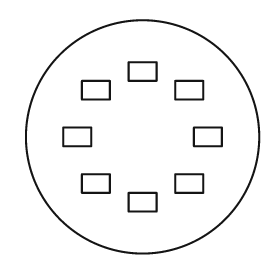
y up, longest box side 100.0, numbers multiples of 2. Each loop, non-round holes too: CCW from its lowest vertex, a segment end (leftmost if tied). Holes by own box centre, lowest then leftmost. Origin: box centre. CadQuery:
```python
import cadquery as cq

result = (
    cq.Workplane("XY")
    .moveTo(0.0, 0.0)
    .circle(50.0)
    .moveTo(-6.0, -32.0)
    .lineTo(6.0, -32.0)
    .lineTo(6.0, -24.0)
    .lineTo(-6.0, -24.0)
    .close()
    .moveTo(-26.0, -24.0)
    .lineTo(-14.0, -24.0)
    .lineTo(-14.0, -16.0)
    .lineTo(-26.0, -16.0)
    .close()
    .moveTo(14.0, -24.0)
    .lineTo(26.0, -24.0)
    .lineTo(26.0, -16.0)
    .lineTo(14.0, -16.0)
    .close()
    .moveTo(-34.0, -4.0)
    .lineTo(-22.0, -4.0)
    .lineTo(-22.0, 4.0)
    .lineTo(-34.0, 4.0)
    .close()
    .moveTo(22.0, -4.0)
    .lineTo(34.0, -4.0)
    .lineTo(34.0, 4.0)
    .lineTo(22.0, 4.0)
    .close()
    .moveTo(-26.0, 16.0)
    .lineTo(-14.0, 16.0)
    .lineTo(-14.0, 24.0)
    .lineTo(-26.0, 24.0)
    .close()
    .moveTo(14.0, 16.0)
    .lineTo(26.0, 16.0)
    .lineTo(26.0, 24.0)
    .lineTo(14.0, 24.0)
    .close()
    .moveTo(-6.0, 24.0)
    .lineTo(6.0, 24.0)
    .lineTo(6.0, 32.0)
    .lineTo(-6.0, 32.0)
    .close()
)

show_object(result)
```